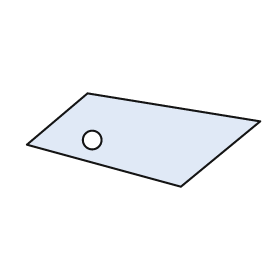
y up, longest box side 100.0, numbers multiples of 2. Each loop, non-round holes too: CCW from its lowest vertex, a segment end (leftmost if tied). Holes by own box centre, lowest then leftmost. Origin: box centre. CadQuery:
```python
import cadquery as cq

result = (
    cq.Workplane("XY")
    .moveTo(16.0, -20.0)
    .lineTo(50.0, 8.0)
    .lineTo(-24.0, 20.0)
    .lineTo(-50.0, -2.0)
    .close()
    .moveTo(-22.0, 0.0)
    .circle(4.0)
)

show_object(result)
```